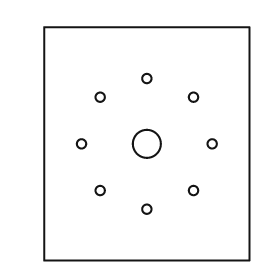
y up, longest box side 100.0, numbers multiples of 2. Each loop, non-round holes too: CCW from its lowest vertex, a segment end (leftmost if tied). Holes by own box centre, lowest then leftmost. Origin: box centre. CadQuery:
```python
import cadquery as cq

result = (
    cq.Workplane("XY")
    .moveTo(-44.0, -50.0)
    .lineTo(44.0, -50.0)
    .lineTo(44.0, 50.0)
    .lineTo(-44.0, 50.0)
    .close()
    .moveTo(0.0, -28.0)
    .circle(2.0)
    .moveTo(-20.0, -20.0)
    .circle(2.0)
    .moveTo(20.0, -20.0)
    .circle(2.0)
    .moveTo(-28.0, 0.0)
    .circle(2.0)
    .moveTo(0.0, 0.0)
    .circle(6.0)
    .moveTo(28.0, 0.0)
    .circle(2.0)
    .moveTo(-20.0, 20.0)
    .circle(2.0)
    .moveTo(20.0, 20.0)
    .circle(2.0)
    .moveTo(0.0, 28.0)
    .circle(2.0)
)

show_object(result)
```